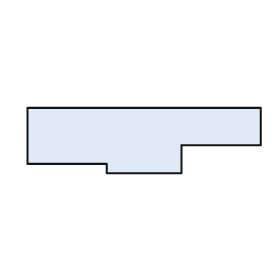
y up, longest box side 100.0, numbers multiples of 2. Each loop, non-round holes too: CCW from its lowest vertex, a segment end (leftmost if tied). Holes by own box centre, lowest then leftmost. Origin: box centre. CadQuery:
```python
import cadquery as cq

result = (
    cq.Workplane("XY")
    .moveTo(-16.0, -14.0)
    .lineTo(16.0, -14.0)
    .lineTo(16.0, -2.0)
    .lineTo(50.0, -2.0)
    .lineTo(50.0, 14.0)
    .lineTo(-50.0, 14.0)
    .lineTo(-50.0, -10.0)
    .lineTo(-16.0, -10.0)
    .close()
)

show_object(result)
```